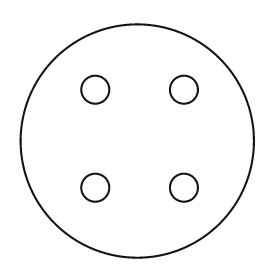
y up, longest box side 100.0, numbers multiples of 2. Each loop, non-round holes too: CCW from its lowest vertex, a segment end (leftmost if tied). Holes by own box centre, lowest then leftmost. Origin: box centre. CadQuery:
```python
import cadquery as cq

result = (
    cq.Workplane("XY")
    .moveTo(0.0, 0.0)
    .circle(50.0)
    .moveTo(-18.0, -20.0)
    .circle(6.0)
    .moveTo(20.0, -20.0)
    .circle(6.0)
    .moveTo(-18.0, 22.0)
    .circle(6.0)
    .moveTo(20.0, 22.0)
    .circle(6.0)
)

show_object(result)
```